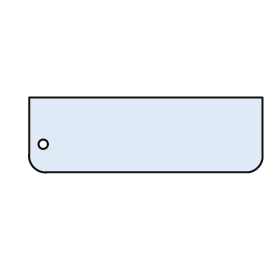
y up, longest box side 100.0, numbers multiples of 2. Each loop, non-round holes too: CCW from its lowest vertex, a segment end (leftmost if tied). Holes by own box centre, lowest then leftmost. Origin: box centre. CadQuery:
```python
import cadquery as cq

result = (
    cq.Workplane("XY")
    .moveTo(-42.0, -16.0)
    .lineTo(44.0, -16.0)
    .threePointArc((48.0, -14.0), (50.0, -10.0))
    .lineTo(50.0, 16.0)
    .lineTo(-50.0, 16.0)
    .lineTo(-50.0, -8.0)
    .threePointArc((-48.0, -14.0), (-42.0, -16.0))
    .close()
    .moveTo(-44.0, -4.0)
    .circle(2.0)
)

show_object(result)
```